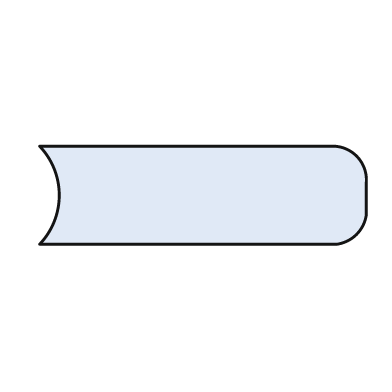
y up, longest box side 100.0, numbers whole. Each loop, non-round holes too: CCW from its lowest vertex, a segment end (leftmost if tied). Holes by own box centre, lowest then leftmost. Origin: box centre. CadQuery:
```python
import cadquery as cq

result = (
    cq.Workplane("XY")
    .moveTo(-50.0, -15.0)
    .lineTo(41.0, -15.0)
    .threePointArc((47.0, -12.0), (50.0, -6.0))
    .lineTo(50.0, 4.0)
    .threePointArc((47.0, 12.0), (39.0, 15.0))
    .lineTo(-50.0, 15.0)
    .threePointArc((-44.0, 0.0), (-50.0, -15.0))
    .close()
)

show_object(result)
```